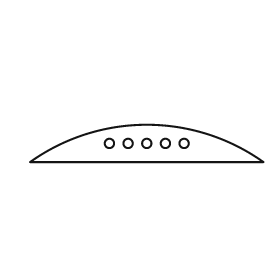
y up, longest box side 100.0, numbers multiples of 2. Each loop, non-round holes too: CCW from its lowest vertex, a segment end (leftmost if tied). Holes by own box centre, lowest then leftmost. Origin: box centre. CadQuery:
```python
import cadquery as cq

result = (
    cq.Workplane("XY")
    .moveTo(-50.0, -8.0)
    .lineTo(50.0, -8.0)
    .threePointArc((0.0, 8.0), (-50.0, -8.0))
    .close()
    .moveTo(-16.0, 0.0)
    .circle(2.0)
    .moveTo(-8.0, 0.0)
    .circle(2.0)
    .moveTo(0.0, 0.0)
    .circle(2.0)
    .moveTo(8.0, 0.0)
    .circle(2.0)
    .moveTo(16.0, 0.0)
    .circle(2.0)
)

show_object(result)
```